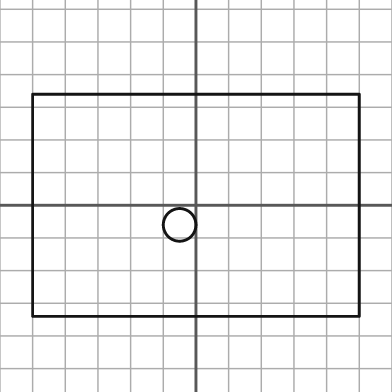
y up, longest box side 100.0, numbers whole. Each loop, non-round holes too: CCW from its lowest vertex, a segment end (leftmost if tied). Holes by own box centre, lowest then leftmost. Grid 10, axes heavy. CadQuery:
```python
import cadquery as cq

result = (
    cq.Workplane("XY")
    .moveTo(-50.0, -34.0)
    .lineTo(50.0, -34.0)
    .lineTo(50.0, 34.0)
    .lineTo(-50.0, 34.0)
    .close()
    .moveTo(-5.0, -6.0)
    .circle(5.0)
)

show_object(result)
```